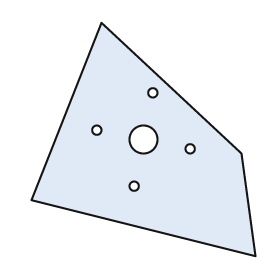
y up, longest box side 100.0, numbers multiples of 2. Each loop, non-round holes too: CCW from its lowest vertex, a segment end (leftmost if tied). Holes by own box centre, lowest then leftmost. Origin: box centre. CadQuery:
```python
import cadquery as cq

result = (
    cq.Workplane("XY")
    .moveTo(48.0, -50.0)
    .lineTo(42.0, -6.0)
    .lineTo(-18.0, 50.0)
    .lineTo(-48.0, -26.0)
    .close()
    .moveTo(-4.0, -20.0)
    .circle(2.0)
    .moveTo(20.0, -4.0)
    .circle(2.0)
    .moveTo(0.0, 0.0)
    .circle(6.0)
    .moveTo(-20.0, 4.0)
    .circle(2.0)
    .moveTo(4.0, 20.0)
    .circle(2.0)
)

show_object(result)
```